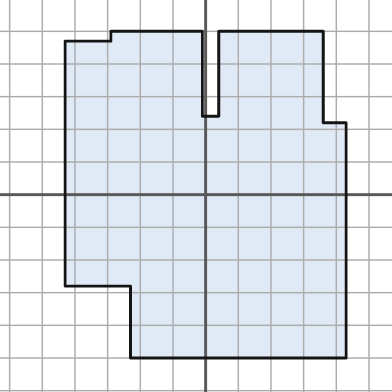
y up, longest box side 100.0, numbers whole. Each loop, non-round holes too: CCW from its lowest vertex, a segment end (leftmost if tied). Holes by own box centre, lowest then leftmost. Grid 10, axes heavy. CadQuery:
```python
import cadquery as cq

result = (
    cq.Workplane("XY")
    .moveTo(-23.0, -50.0)
    .lineTo(43.0, -50.0)
    .lineTo(43.0, 22.0)
    .lineTo(36.0, 22.0)
    .lineTo(36.0, 50.0)
    .lineTo(4.0, 50.0)
    .lineTo(4.0, 24.0)
    .lineTo(-1.0, 24.0)
    .lineTo(-1.0, 50.0)
    .lineTo(-29.0, 50.0)
    .lineTo(-29.0, 47.0)
    .lineTo(-43.0, 47.0)
    .lineTo(-43.0, -28.0)
    .lineTo(-23.0, -28.0)
    .close()
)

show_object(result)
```